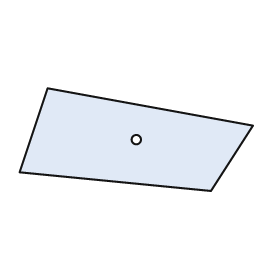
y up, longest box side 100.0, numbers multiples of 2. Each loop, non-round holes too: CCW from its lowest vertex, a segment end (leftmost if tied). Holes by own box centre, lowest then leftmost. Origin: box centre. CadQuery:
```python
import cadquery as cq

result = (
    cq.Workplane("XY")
    .moveTo(32.0, -22.0)
    .lineTo(50.0, 6.0)
    .lineTo(-38.0, 22.0)
    .lineTo(-50.0, -14.0)
    .close()
    .moveTo(0.0, 0.0)
    .circle(2.0)
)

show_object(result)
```